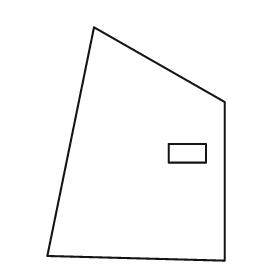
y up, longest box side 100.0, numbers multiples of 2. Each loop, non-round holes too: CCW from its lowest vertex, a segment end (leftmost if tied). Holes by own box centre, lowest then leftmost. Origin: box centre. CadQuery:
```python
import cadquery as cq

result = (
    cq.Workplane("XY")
    .moveTo(38.0, -50.0)
    .lineTo(38.0, 18.0)
    .lineTo(-18.0, 50.0)
    .lineTo(-38.0, -48.0)
    .close()
    .moveTo(14.0, -8.0)
    .lineTo(30.0, -8.0)
    .lineTo(30.0, 0.0)
    .lineTo(14.0, 0.0)
    .close()
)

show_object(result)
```